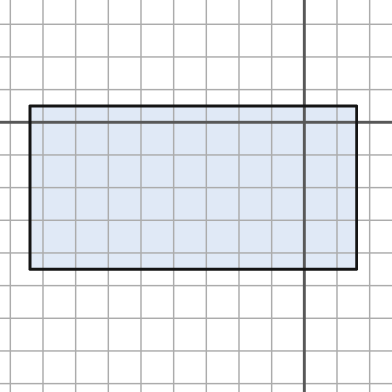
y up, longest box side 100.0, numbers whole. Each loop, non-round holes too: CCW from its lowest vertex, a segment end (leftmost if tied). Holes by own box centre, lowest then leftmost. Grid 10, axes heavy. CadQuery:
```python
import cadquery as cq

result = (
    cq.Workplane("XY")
    .moveTo(-84.0, -45.0)
    .lineTo(16.0, -45.0)
    .lineTo(16.0, 5.0)
    .lineTo(-84.0, 5.0)
    .close()
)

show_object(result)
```